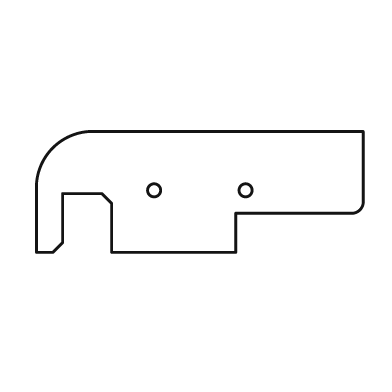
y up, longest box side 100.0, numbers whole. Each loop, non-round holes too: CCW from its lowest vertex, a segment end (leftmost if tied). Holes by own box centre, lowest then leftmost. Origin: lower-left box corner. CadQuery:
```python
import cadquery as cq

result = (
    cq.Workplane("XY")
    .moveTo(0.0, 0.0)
    .lineTo(5.0, 0.0)
    .lineTo(8.0, 3.0)
    .lineTo(8.0, 18.0)
    .lineTo(20.0, 18.0)
    .lineTo(23.0, 15.0)
    .lineTo(23.0, 0.0)
    .lineTo(61.0, 0.0)
    .lineTo(61.0, 12.0)
    .lineTo(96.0, 12.0)
    .threePointArc((99.0, 13.0), (100.0, 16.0))
    .lineTo(100.0, 37.0)
    .lineTo(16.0, 37.0)
    .threePointArc((5.0, 32.0), (0.0, 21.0))
    .close()
    .moveTo(36.0, 19.0)
    .circle(2.0)
    .moveTo(64.0, 19.0)
    .circle(2.0)
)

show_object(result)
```